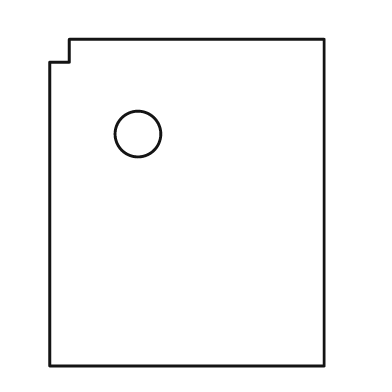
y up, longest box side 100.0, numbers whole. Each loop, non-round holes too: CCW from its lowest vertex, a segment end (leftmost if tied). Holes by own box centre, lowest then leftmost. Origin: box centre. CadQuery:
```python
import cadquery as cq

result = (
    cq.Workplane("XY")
    .moveTo(-42.0, -50.0)
    .lineTo(42.0, -50.0)
    .lineTo(42.0, 50.0)
    .lineTo(-36.0, 50.0)
    .lineTo(-36.0, 43.0)
    .lineTo(-42.0, 43.0)
    .close()
    .moveTo(-15.0, 21.0)
    .circle(7.0)
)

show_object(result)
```